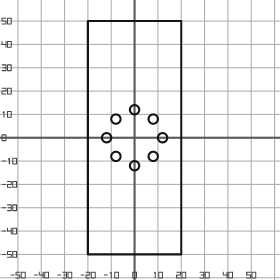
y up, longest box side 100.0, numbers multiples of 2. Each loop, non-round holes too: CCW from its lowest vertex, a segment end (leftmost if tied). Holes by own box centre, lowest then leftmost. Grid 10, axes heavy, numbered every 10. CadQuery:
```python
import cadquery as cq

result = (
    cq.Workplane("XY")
    .moveTo(-20.0, -50.0)
    .lineTo(20.0, -50.0)
    .lineTo(20.0, 50.0)
    .lineTo(-20.0, 50.0)
    .close()
    .moveTo(0.0, -12.0)
    .circle(2.0)
    .moveTo(-8.0, -8.0)
    .circle(2.0)
    .moveTo(8.0, -8.0)
    .circle(2.0)
    .moveTo(-12.0, 0.0)
    .circle(2.0)
    .moveTo(12.0, 0.0)
    .circle(2.0)
    .moveTo(-8.0, 8.0)
    .circle(2.0)
    .moveTo(8.0, 8.0)
    .circle(2.0)
    .moveTo(0.0, 12.0)
    .circle(2.0)
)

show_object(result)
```